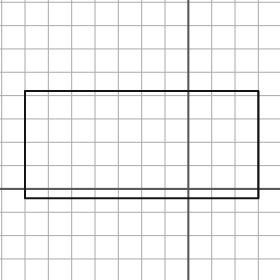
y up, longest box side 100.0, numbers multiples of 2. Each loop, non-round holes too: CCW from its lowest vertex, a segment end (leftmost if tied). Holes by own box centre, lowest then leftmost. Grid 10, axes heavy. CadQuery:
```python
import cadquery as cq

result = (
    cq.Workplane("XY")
    .moveTo(-70.0, -4.0)
    .lineTo(30.0, -4.0)
    .lineTo(30.0, 42.0)
    .lineTo(-70.0, 42.0)
    .close()
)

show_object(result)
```